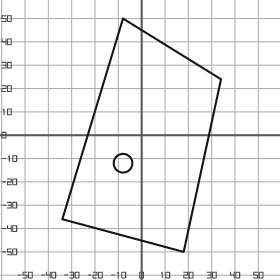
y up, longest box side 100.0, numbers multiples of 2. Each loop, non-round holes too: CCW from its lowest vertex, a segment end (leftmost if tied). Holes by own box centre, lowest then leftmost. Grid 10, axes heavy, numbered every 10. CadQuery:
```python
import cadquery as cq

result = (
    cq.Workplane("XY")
    .moveTo(18.0, -50.0)
    .lineTo(34.0, 24.0)
    .lineTo(-8.0, 50.0)
    .lineTo(-34.0, -36.0)
    .close()
    .moveTo(-8.0, -12.0)
    .circle(4.0)
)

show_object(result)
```